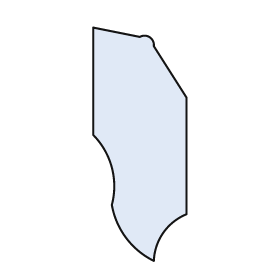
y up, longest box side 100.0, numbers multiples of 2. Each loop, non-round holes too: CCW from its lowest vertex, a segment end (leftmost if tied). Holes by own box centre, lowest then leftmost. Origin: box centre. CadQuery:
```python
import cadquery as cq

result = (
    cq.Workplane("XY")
    .moveTo(6.0, -50.0)
    .threePointArc((10.0, -38.0), (20.0, -30.0))
    .lineTo(20.0, 20.0)
    .lineTo(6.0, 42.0)
    .threePointArc((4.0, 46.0), (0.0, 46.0))
    .lineTo(-20.0, 50.0)
    .lineTo(-20.0, 4.0)
    .threePointArc((-12.0, -10.0), (-12.0, -26.0))
    .threePointArc((-6.0, -40.0), (6.0, -50.0))
    .close()
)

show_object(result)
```